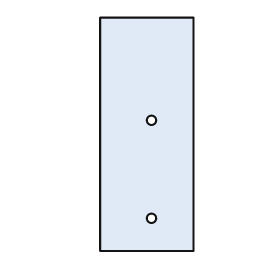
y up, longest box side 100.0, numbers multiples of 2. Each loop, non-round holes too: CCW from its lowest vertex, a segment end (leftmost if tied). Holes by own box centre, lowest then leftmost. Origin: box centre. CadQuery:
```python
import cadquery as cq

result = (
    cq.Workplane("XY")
    .moveTo(-20.0, -50.0)
    .lineTo(20.0, -50.0)
    .lineTo(20.0, 50.0)
    .lineTo(-20.0, 50.0)
    .close()
    .moveTo(2.0, -36.0)
    .circle(2.0)
    .moveTo(2.0, 6.0)
    .circle(2.0)
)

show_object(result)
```